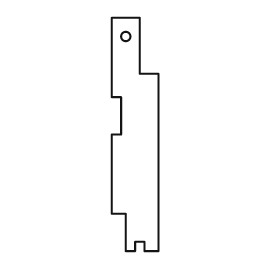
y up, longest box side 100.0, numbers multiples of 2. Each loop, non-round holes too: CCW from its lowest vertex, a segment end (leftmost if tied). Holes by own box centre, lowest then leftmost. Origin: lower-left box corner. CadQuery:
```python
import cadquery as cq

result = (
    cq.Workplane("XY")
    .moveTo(6.0, 0.0)
    .lineTo(10.0, 0.0)
    .lineTo(10.0, 4.0)
    .lineTo(14.0, 4.0)
    .lineTo(14.0, 0.0)
    .lineTo(20.0, 0.0)
    .lineTo(20.0, 76.0)
    .lineTo(12.0, 76.0)
    .lineTo(12.0, 100.0)
    .lineTo(0.0, 100.0)
    .lineTo(0.0, 66.0)
    .lineTo(4.0, 66.0)
    .lineTo(4.0, 50.0)
    .lineTo(0.0, 50.0)
    .lineTo(0.0, 16.0)
    .lineTo(6.0, 16.0)
    .close()
    .moveTo(6.0, 92.0)
    .circle(2.0)
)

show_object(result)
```